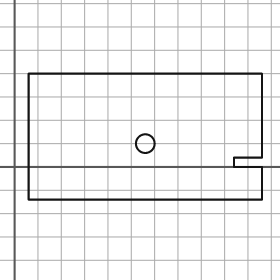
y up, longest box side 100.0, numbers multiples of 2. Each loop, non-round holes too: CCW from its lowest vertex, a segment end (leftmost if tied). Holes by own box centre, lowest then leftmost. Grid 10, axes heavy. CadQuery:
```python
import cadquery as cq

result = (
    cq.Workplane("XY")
    .moveTo(6.0, -14.0)
    .lineTo(106.0, -14.0)
    .lineTo(106.0, 0.0)
    .lineTo(94.0, 0.0)
    .lineTo(94.0, 4.0)
    .lineTo(106.0, 4.0)
    .lineTo(106.0, 40.0)
    .lineTo(6.0, 40.0)
    .close()
    .moveTo(56.0, 10.0)
    .circle(4.0)
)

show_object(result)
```